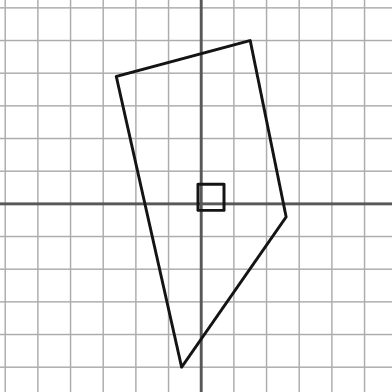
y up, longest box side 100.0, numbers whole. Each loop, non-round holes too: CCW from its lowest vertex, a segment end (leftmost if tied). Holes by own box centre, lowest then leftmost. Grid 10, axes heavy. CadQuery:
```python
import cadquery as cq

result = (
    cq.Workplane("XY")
    .moveTo(-6.0, -50.0)
    .lineTo(26.0, -4.0)
    .lineTo(15.0, 50.0)
    .lineTo(-26.0, 39.0)
    .close()
    .moveTo(-1.0, -2.0)
    .lineTo(7.0, -2.0)
    .lineTo(7.0, 6.0)
    .lineTo(-1.0, 6.0)
    .close()
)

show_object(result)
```